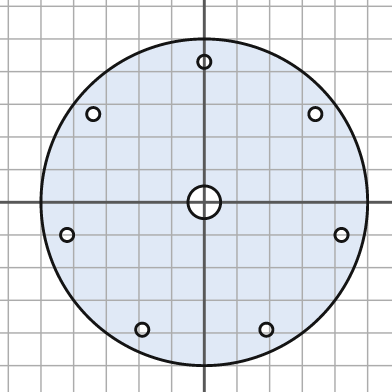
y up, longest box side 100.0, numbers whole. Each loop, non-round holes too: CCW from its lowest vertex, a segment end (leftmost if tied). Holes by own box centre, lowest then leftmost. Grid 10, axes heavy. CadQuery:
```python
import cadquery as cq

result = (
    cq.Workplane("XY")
    .moveTo(0.0, 0.0)
    .circle(50.0)
    .moveTo(-19.0, -39.0)
    .circle(2.0)
    .moveTo(19.0, -39.0)
    .circle(2.0)
    .moveTo(-42.0, -10.0)
    .circle(2.0)
    .moveTo(42.0, -10.0)
    .circle(2.0)
    .moveTo(0.0, 0.0)
    .circle(5.0)
    .moveTo(-34.0, 27.0)
    .circle(2.0)
    .moveTo(34.0, 27.0)
    .circle(2.0)
    .moveTo(0.0, 43.0)
    .circle(2.0)
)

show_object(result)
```